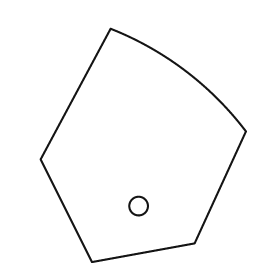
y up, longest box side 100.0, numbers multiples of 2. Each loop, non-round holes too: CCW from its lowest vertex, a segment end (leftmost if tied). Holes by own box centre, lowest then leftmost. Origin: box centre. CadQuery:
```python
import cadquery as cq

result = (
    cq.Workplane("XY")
    .moveTo(-22.0, -50.0)
    .lineTo(22.0, -42.0)
    .lineTo(44.0, 6.0)
    .threePointArc((18.0, 32.0), (-14.0, 50.0))
    .lineTo(-44.0, -6.0)
    .close()
    .moveTo(-2.0, -26.0)
    .circle(4.0)
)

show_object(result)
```